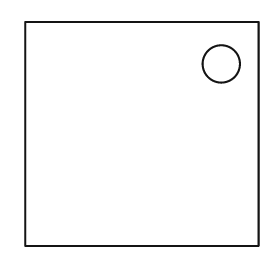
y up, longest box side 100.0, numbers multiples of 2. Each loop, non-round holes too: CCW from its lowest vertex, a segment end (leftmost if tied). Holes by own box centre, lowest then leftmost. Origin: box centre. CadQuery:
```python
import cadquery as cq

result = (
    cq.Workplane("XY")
    .moveTo(-50.0, -48.0)
    .lineTo(50.0, -48.0)
    .lineTo(50.0, 48.0)
    .lineTo(-50.0, 48.0)
    .close()
    .moveTo(34.0, 30.0)
    .circle(8.0)
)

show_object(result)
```